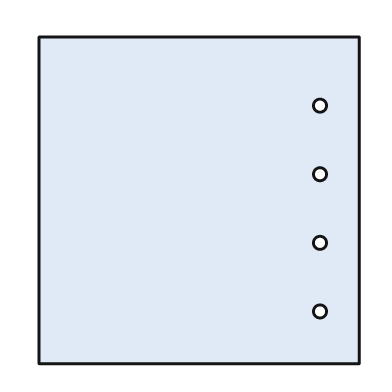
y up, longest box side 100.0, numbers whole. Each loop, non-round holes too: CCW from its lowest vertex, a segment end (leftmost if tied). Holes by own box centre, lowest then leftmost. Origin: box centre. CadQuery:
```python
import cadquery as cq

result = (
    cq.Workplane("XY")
    .moveTo(-49.0, -50.0)
    .lineTo(49.0, -50.0)
    .lineTo(49.0, 50.0)
    .lineTo(-49.0, 50.0)
    .close()
    .moveTo(37.0, -34.0)
    .circle(2.0)
    .moveTo(37.0, -13.0)
    .circle(2.0)
    .moveTo(37.0, 8.0)
    .circle(2.0)
    .moveTo(37.0, 29.0)
    .circle(2.0)
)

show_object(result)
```